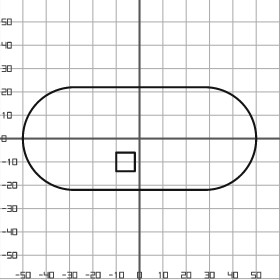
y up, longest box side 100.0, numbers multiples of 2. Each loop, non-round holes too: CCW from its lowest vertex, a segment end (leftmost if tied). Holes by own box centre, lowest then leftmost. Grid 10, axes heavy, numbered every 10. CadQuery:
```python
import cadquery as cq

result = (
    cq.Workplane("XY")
    .moveTo(-28.0, -22.0)
    .lineTo(28.0, -22.0)
    .threePointArc((50.0, 0.0), (28.0, 22.0))
    .lineTo(-28.0, 22.0)
    .threePointArc((-50.0, 0.0), (-28.0, -22.0))
    .close()
    .moveTo(-10.0, -14.0)
    .lineTo(-2.0, -14.0)
    .lineTo(-2.0, -6.0)
    .lineTo(-10.0, -6.0)
    .close()
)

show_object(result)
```